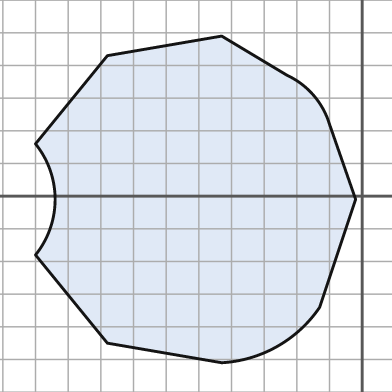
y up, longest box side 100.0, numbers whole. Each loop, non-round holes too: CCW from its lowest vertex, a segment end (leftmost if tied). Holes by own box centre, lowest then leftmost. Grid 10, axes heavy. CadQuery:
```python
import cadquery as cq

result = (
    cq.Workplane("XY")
    .moveTo(-43.0, -51.0)
    .threePointArc((-26.0, -46.0), (-13.0, -34.0))
    .lineTo(-2.0, -1.0)
    .lineTo(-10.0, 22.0)
    .threePointArc((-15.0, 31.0), (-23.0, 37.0))
    .lineTo(-43.0, 49.0)
    .lineTo(-78.0, 43.0)
    .lineTo(-100.0, 16.0)
    .threePointArc((-94.0, -1.0), (-100.0, -18.0))
    .lineTo(-78.0, -45.0)
    .close()
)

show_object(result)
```